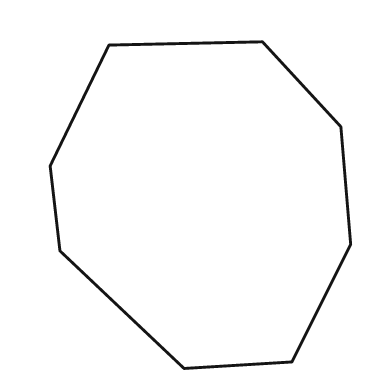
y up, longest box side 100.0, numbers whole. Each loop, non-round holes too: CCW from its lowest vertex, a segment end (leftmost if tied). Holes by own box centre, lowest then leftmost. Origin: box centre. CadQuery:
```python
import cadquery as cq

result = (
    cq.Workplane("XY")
    .moveTo(-5.0, -50.0)
    .lineTo(28.0, -48.0)
    .lineTo(46.0, -12.0)
    .lineTo(43.0, 24.0)
    .lineTo(19.0, 50.0)
    .lineTo(-28.0, 49.0)
    .lineTo(-46.0, 12.0)
    .lineTo(-43.0, -14.0)
    .close()
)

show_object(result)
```